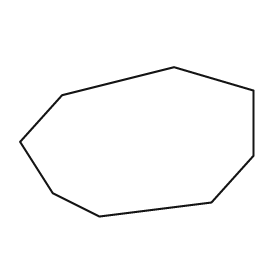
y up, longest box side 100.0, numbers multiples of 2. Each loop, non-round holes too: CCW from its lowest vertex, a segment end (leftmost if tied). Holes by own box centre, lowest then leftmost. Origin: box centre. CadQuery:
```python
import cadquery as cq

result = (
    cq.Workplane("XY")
    .moveTo(-16.0, -32.0)
    .lineTo(32.0, -26.0)
    .lineTo(50.0, -6.0)
    .lineTo(50.0, 22.0)
    .lineTo(16.0, 32.0)
    .lineTo(-32.0, 20.0)
    .lineTo(-50.0, 0.0)
    .lineTo(-36.0, -22.0)
    .close()
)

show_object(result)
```